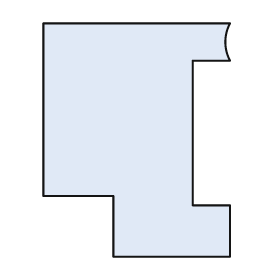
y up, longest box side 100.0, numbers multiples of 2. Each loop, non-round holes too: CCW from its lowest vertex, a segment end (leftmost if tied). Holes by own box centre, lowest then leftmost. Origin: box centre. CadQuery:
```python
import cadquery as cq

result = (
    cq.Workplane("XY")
    .moveTo(-10.0, -50.0)
    .lineTo(40.0, -50.0)
    .lineTo(40.0, -28.0)
    .lineTo(24.0, -28.0)
    .lineTo(24.0, 34.0)
    .lineTo(40.0, 34.0)
    .threePointArc((38.0, 42.0), (40.0, 50.0))
    .lineTo(-40.0, 50.0)
    .lineTo(-40.0, -24.0)
    .lineTo(-10.0, -24.0)
    .close()
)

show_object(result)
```